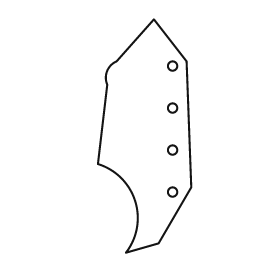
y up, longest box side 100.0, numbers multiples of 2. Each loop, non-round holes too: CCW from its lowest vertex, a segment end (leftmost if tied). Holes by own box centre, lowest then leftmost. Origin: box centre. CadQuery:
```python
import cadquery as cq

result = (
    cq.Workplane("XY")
    .moveTo(-8.0, -50.0)
    .lineTo(6.0, -46.0)
    .lineTo(20.0, -22.0)
    .lineTo(18.0, 32.0)
    .lineTo(4.0, 50.0)
    .lineTo(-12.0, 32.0)
    .threePointArc((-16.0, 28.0), (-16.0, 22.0))
    .lineTo(-20.0, -12.0)
    .threePointArc((-4.0, -28.0), (-8.0, -50.0))
    .close()
    .moveTo(12.0, -24.0)
    .circle(2.0)
    .moveTo(12.0, -6.0)
    .circle(2.0)
    .moveTo(12.0, 12.0)
    .circle(2.0)
    .moveTo(12.0, 30.0)
    .circle(2.0)
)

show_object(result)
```